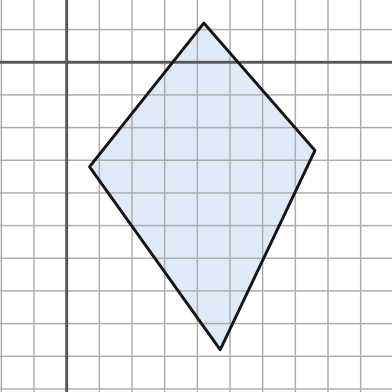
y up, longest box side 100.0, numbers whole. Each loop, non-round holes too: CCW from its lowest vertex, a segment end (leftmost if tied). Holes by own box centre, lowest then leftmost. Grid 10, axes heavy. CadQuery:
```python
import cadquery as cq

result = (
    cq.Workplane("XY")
    .moveTo(47.0, -88.0)
    .lineTo(76.0, -27.0)
    .lineTo(42.0, 12.0)
    .lineTo(7.0, -32.0)
    .close()
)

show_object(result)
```